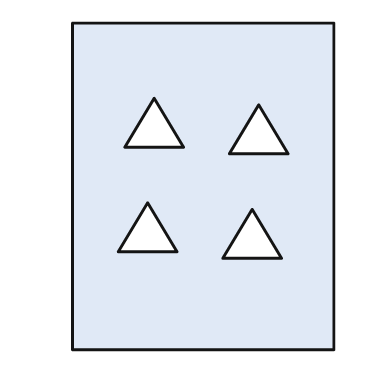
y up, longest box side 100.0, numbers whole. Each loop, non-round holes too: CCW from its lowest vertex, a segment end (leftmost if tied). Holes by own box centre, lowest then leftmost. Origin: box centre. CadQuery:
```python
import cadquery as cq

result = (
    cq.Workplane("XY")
    .moveTo(-40.0, -50.0)
    .lineTo(40.0, -50.0)
    .lineTo(40.0, 50.0)
    .lineTo(-40.0, 50.0)
    .close()
    .moveTo(6.0, -22.0)
    .lineTo(24.0, -22.0)
    .lineTo(15.0, -7.0)
    .close()
    .moveTo(-26.0, -20.0)
    .lineTo(-8.0, -20.0)
    .lineTo(-17.0, -5.0)
    .close()
    .moveTo(8.0, 10.0)
    .lineTo(26.0, 10.0)
    .lineTo(17.0, 25.0)
    .close()
    .moveTo(-24.0, 12.0)
    .lineTo(-6.0, 12.0)
    .lineTo(-15.0, 27.0)
    .close()
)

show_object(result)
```